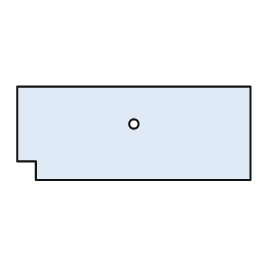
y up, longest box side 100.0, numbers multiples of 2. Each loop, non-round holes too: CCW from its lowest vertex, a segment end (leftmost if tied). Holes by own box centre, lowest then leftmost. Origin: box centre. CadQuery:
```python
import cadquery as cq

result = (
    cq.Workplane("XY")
    .moveTo(-42.0, -20.0)
    .lineTo(50.0, -20.0)
    .lineTo(50.0, 20.0)
    .lineTo(-50.0, 20.0)
    .lineTo(-50.0, -12.0)
    .lineTo(-42.0, -12.0)
    .close()
    .moveTo(0.0, 4.0)
    .circle(2.0)
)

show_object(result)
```